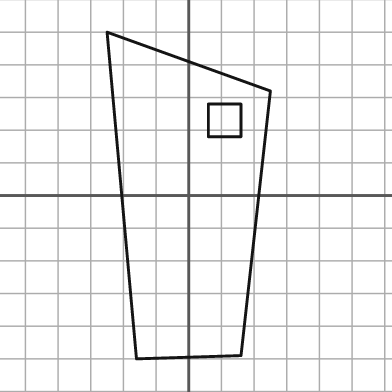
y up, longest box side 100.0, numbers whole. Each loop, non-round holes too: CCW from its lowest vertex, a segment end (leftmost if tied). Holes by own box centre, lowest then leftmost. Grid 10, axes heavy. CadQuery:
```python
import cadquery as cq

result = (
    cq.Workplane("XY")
    .moveTo(-16.0, -50.0)
    .lineTo(16.0, -49.0)
    .lineTo(25.0, 32.0)
    .lineTo(-25.0, 50.0)
    .close()
    .moveTo(6.0, 18.0)
    .lineTo(16.0, 18.0)
    .lineTo(16.0, 28.0)
    .lineTo(6.0, 28.0)
    .close()
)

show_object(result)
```